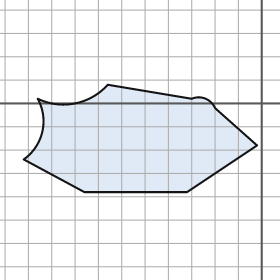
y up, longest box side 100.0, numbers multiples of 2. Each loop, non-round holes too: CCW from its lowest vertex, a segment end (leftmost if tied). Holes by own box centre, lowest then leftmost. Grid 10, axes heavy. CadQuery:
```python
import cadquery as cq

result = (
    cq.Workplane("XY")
    .moveTo(-76.0, -38.0)
    .lineTo(-32.0, -38.0)
    .lineTo(-2.0, -18.0)
    .lineTo(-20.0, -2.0)
    .threePointArc((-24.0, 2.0), (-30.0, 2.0))
    .lineTo(-66.0, 8.0)
    .threePointArc((-80.0, 0.0), (-96.0, 2.0))
    .threePointArc((-94.0, -12.0), (-102.0, -24.0))
    .close()
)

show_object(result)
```